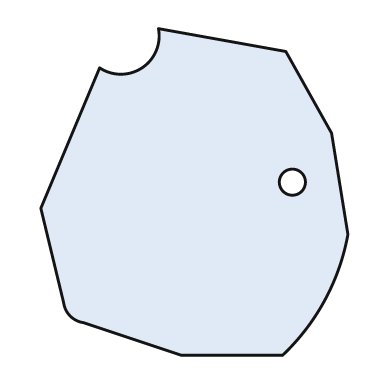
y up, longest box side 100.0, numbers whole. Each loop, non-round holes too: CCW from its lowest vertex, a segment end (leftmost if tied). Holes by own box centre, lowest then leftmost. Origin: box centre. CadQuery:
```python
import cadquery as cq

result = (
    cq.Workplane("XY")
    .moveTo(-4.0, -50.0)
    .lineTo(27.0, -50.0)
    .threePointArc((40.0, -33.0), (47.0, -13.0))
    .lineTo(42.0, 18.0)
    .lineTo(28.0, 43.0)
    .lineTo(-11.0, 50.0)
    .threePointArc((-16.0, 38.0), (-29.0, 38.0))
    .lineTo(-47.0, -5.0)
    .lineTo(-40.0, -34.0)
    .threePointArc((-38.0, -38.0), (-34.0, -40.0))
    .close()
    .moveTo(30.0, 3.0)
    .circle(4.0)
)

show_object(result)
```